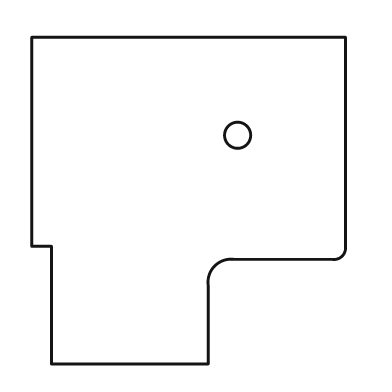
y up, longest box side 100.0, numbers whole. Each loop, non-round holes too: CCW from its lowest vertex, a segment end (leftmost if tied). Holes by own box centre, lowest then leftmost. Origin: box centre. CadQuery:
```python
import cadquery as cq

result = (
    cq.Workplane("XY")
    .moveTo(-42.0, -50.0)
    .lineTo(6.0, -50.0)
    .lineTo(6.0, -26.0)
    .threePointArc((8.0, -20.0), (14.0, -18.0))
    .lineTo(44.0, -18.0)
    .threePointArc((47.0, -17.0), (48.0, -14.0))
    .lineTo(48.0, 50.0)
    .lineTo(-48.0, 50.0)
    .lineTo(-48.0, -14.0)
    .lineTo(-42.0, -14.0)
    .close()
    .moveTo(15.0, 20.0)
    .circle(4.0)
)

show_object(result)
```